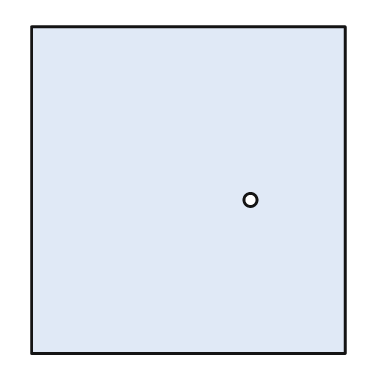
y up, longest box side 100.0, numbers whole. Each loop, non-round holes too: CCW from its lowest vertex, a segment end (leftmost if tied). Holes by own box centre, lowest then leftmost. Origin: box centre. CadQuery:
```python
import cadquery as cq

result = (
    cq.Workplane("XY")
    .moveTo(-48.0, -50.0)
    .lineTo(48.0, -50.0)
    .lineTo(48.0, 50.0)
    .lineTo(-48.0, 50.0)
    .close()
    .moveTo(19.0, -3.0)
    .circle(2.0)
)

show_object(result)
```